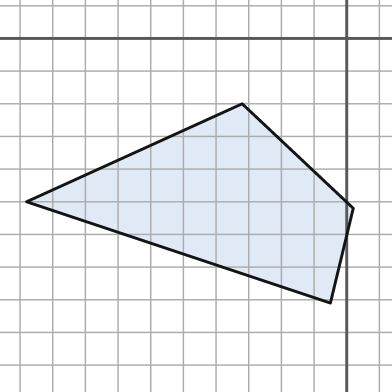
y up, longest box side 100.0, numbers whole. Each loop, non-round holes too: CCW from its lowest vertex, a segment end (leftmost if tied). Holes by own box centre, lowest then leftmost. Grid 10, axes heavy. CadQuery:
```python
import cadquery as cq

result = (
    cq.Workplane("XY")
    .moveTo(-5.0, -81.0)
    .lineTo(2.0, -52.0)
    .lineTo(-32.0, -20.0)
    .lineTo(-98.0, -50.0)
    .close()
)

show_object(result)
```